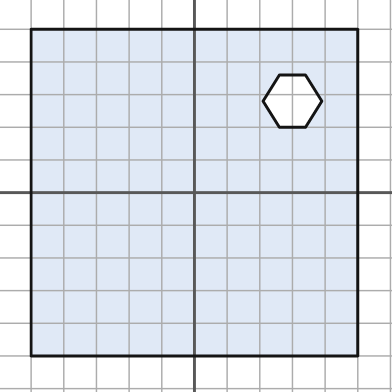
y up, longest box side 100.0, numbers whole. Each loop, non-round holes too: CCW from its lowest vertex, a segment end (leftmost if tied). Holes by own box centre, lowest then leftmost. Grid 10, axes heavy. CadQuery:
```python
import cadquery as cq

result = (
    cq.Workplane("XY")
    .moveTo(-50.0, -50.0)
    .lineTo(50.0, -50.0)
    .lineTo(50.0, 50.0)
    .lineTo(-50.0, 50.0)
    .close()
    .moveTo(26.0, 20.0)
    .lineTo(34.0, 20.0)
    .lineTo(39.0, 28.0)
    .lineTo(34.0, 36.0)
    .lineTo(26.0, 36.0)
    .lineTo(21.0, 28.0)
    .close()
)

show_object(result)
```